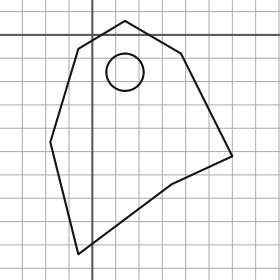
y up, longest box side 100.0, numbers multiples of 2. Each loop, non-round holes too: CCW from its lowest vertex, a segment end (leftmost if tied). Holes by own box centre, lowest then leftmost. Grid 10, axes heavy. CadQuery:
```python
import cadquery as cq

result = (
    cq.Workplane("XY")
    .moveTo(-6.0, -94.0)
    .lineTo(34.0, -64.0)
    .lineTo(60.0, -52.0)
    .lineTo(38.0, -8.0)
    .lineTo(14.0, 6.0)
    .lineTo(-6.0, -6.0)
    .lineTo(-18.0, -46.0)
    .close()
    .moveTo(14.0, -16.0)
    .circle(8.0)
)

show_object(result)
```